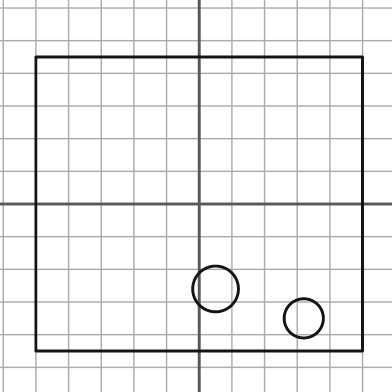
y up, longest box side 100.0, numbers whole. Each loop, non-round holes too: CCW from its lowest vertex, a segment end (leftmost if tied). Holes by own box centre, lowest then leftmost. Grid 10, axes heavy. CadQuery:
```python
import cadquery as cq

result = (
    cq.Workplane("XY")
    .moveTo(-50.0, -45.0)
    .lineTo(50.0, -45.0)
    .lineTo(50.0, 45.0)
    .lineTo(-50.0, 45.0)
    .close()
    .moveTo(32.0, -35.0)
    .circle(6.0)
    .moveTo(5.0, -26.0)
    .circle(7.0)
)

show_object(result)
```